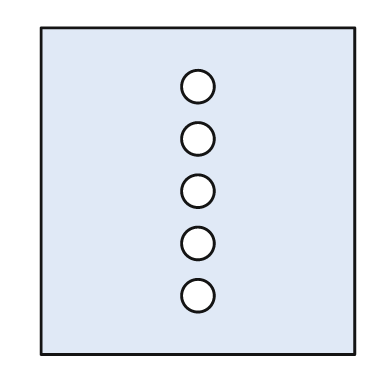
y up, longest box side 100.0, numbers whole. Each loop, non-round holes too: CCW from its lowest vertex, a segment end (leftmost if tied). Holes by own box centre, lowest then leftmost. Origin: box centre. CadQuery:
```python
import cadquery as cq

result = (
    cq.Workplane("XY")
    .moveTo(-48.0, -50.0)
    .lineTo(48.0, -50.0)
    .lineTo(48.0, 50.0)
    .lineTo(-48.0, 50.0)
    .close()
    .moveTo(0.0, -32.0)
    .circle(5.0)
    .moveTo(0.0, -16.0)
    .circle(5.0)
    .moveTo(0.0, 0.0)
    .circle(5.0)
    .moveTo(0.0, 16.0)
    .circle(5.0)
    .moveTo(0.0, 32.0)
    .circle(5.0)
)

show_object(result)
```